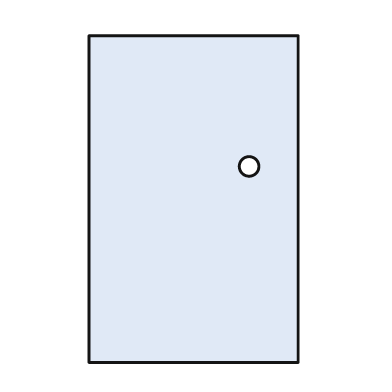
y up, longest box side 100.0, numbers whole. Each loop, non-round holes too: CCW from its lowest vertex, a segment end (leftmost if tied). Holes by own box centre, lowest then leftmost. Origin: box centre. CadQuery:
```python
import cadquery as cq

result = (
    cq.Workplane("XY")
    .moveTo(-32.0, -50.0)
    .lineTo(32.0, -50.0)
    .lineTo(32.0, 50.0)
    .lineTo(-32.0, 50.0)
    .close()
    .moveTo(17.0, 10.0)
    .circle(3.0)
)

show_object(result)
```